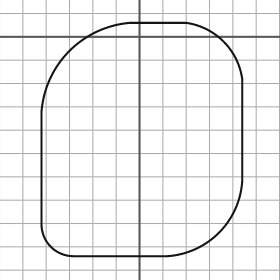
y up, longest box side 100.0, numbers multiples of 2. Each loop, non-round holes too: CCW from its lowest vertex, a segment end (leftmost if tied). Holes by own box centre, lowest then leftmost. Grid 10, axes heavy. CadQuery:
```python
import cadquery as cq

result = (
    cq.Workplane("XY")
    .moveTo(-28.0, -94.0)
    .lineTo(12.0, -94.0)
    .threePointArc((34.0, -84.0), (44.0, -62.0))
    .lineTo(44.0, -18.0)
    .threePointArc((36.0, -2.0), (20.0, 6.0))
    .lineTo(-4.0, 6.0)
    .threePointArc((-30.0, -6.0), (-42.0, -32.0))
    .lineTo(-42.0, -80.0)
    .threePointArc((-38.0, -90.0), (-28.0, -94.0))
    .close()
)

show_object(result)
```